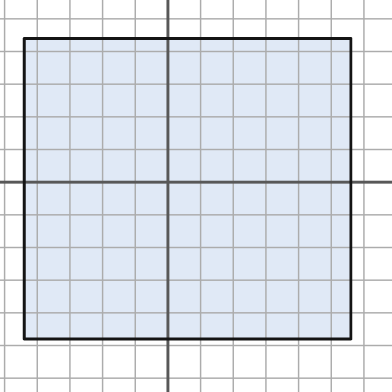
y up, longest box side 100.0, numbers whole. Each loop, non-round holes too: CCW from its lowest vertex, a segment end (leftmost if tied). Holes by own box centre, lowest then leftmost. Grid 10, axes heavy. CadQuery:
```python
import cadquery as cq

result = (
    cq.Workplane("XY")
    .moveTo(-44.0, -48.0)
    .lineTo(56.0, -48.0)
    .lineTo(56.0, 44.0)
    .lineTo(-44.0, 44.0)
    .close()
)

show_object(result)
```